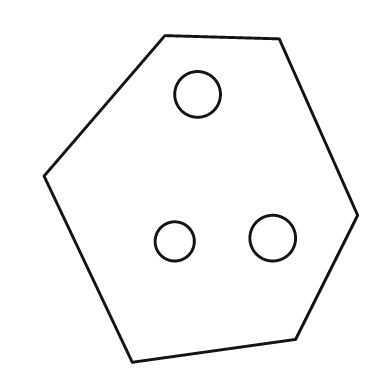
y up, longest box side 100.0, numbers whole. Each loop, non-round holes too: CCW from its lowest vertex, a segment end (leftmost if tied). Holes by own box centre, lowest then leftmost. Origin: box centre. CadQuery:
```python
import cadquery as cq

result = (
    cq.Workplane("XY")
    .moveTo(-21.0, -50.0)
    .lineTo(29.0, -43.0)
    .lineTo(48.0, -5.0)
    .lineTo(24.0, 49.0)
    .lineTo(-11.0, 50.0)
    .lineTo(-48.0, 7.0)
    .close()
    .moveTo(-8.0, -13.0)
    .circle(6.0)
    .moveTo(22.0, -12.0)
    .circle(7.0)
    .moveTo(-1.0, 32.0)
    .circle(7.0)
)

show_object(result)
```